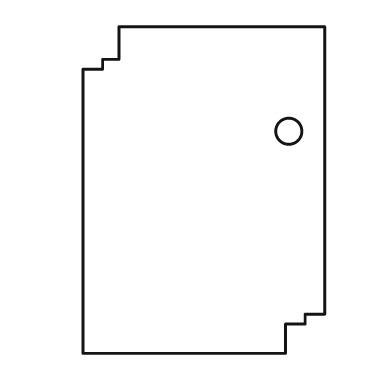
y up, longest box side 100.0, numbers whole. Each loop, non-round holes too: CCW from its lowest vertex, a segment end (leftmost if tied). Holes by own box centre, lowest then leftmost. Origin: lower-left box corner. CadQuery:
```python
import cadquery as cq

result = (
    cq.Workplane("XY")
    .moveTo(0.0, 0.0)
    .lineTo(62.0, 0.0)
    .lineTo(62.0, 9.0)
    .lineTo(68.0, 9.0)
    .lineTo(68.0, 12.0)
    .lineTo(74.0, 12.0)
    .lineTo(74.0, 100.0)
    .lineTo(11.0, 100.0)
    .lineTo(11.0, 90.0)
    .lineTo(6.0, 90.0)
    .lineTo(6.0, 87.0)
    .lineTo(0.0, 87.0)
    .close()
    .moveTo(63.0, 68.0)
    .circle(4.0)
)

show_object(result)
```